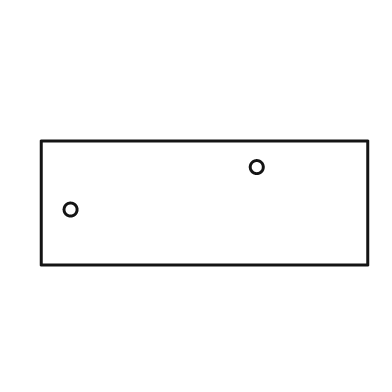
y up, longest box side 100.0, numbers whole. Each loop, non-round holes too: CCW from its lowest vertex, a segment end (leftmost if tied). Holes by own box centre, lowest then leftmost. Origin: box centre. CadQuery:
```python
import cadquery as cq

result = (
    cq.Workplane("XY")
    .moveTo(-50.0, -19.0)
    .lineTo(50.0, -19.0)
    .lineTo(50.0, 19.0)
    .lineTo(-50.0, 19.0)
    .close()
    .moveTo(-41.0, -2.0)
    .circle(2.0)
    .moveTo(16.0, 11.0)
    .circle(2.0)
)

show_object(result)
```